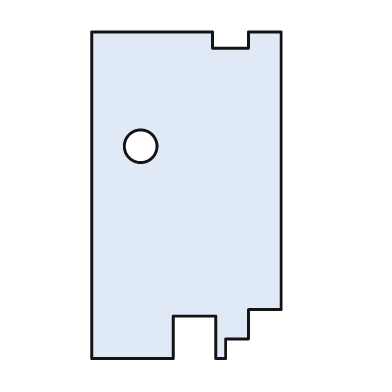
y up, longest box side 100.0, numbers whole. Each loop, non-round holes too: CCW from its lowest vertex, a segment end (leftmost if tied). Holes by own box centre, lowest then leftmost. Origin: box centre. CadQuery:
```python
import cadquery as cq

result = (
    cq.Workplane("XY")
    .moveTo(-29.0, -50.0)
    .lineTo(-4.0, -50.0)
    .lineTo(-4.0, -37.0)
    .lineTo(9.0, -37.0)
    .lineTo(9.0, -50.0)
    .lineTo(12.0, -50.0)
    .lineTo(12.0, -44.0)
    .lineTo(19.0, -44.0)
    .lineTo(19.0, -35.0)
    .lineTo(29.0, -35.0)
    .lineTo(29.0, 50.0)
    .lineTo(19.0, 50.0)
    .lineTo(19.0, 45.0)
    .lineTo(8.0, 45.0)
    .lineTo(8.0, 50.0)
    .lineTo(-29.0, 50.0)
    .close()
    .moveTo(-14.0, 15.0)
    .circle(5.0)
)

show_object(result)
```